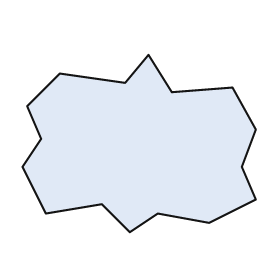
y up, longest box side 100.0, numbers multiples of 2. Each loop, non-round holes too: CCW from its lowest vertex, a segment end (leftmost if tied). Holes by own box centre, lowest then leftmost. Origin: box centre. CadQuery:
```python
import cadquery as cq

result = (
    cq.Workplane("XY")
    .moveTo(-4.0, -38.0)
    .lineTo(8.0, -30.0)
    .lineTo(30.0, -34.0)
    .lineTo(50.0, -24.0)
    .lineTo(44.0, -10.0)
    .lineTo(50.0, 6.0)
    .lineTo(40.0, 24.0)
    .lineTo(14.0, 22.0)
    .lineTo(4.0, 38.0)
    .lineTo(-6.0, 26.0)
    .lineTo(-34.0, 30.0)
    .lineTo(-48.0, 16.0)
    .lineTo(-42.0, 2.0)
    .lineTo(-50.0, -10.0)
    .lineTo(-40.0, -30.0)
    .lineTo(-16.0, -26.0)
    .close()
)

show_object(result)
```